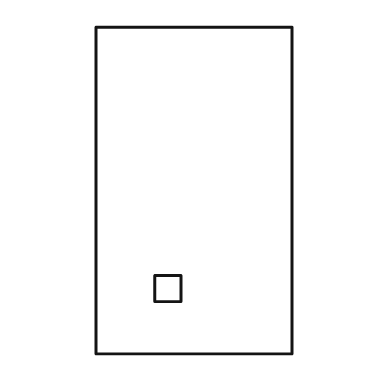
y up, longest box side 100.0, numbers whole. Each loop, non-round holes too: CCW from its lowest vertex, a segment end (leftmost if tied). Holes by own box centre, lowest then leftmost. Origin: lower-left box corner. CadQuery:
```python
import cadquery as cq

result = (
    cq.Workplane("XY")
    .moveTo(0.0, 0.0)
    .lineTo(60.0, 0.0)
    .lineTo(60.0, 100.0)
    .lineTo(0.0, 100.0)
    .close()
    .moveTo(18.0, 16.0)
    .lineTo(26.0, 16.0)
    .lineTo(26.0, 24.0)
    .lineTo(18.0, 24.0)
    .close()
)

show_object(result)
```